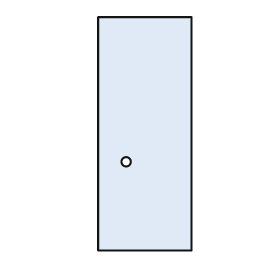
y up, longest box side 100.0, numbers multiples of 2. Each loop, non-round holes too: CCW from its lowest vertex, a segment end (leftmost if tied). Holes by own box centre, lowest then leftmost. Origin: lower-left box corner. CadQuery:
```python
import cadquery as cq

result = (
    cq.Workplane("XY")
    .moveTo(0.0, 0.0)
    .lineTo(40.0, 0.0)
    .lineTo(40.0, 100.0)
    .lineTo(0.0, 100.0)
    .close()
    .moveTo(12.0, 38.0)
    .circle(2.0)
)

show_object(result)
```